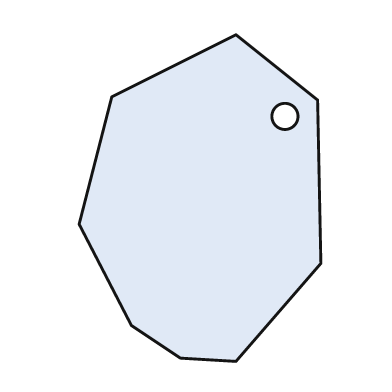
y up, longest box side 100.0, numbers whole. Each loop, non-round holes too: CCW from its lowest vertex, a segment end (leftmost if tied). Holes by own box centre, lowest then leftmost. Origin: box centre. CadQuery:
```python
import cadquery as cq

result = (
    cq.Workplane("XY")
    .moveTo(11.0, -50.0)
    .lineTo(37.0, -20.0)
    .lineTo(36.0, 30.0)
    .lineTo(11.0, 50.0)
    .lineTo(-27.0, 31.0)
    .lineTo(-37.0, -8.0)
    .lineTo(-21.0, -39.0)
    .lineTo(-6.0, -49.0)
    .close()
    .moveTo(26.0, 25.0)
    .circle(4.0)
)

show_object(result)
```